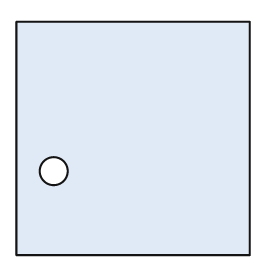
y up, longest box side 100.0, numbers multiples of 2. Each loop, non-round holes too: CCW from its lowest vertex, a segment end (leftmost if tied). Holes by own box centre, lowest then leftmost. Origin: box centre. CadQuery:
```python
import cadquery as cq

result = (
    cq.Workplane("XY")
    .moveTo(-50.0, -50.0)
    .lineTo(50.0, -50.0)
    .lineTo(50.0, 50.0)
    .lineTo(-50.0, 50.0)
    .close()
    .moveTo(-34.0, -14.0)
    .circle(6.0)
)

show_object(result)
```